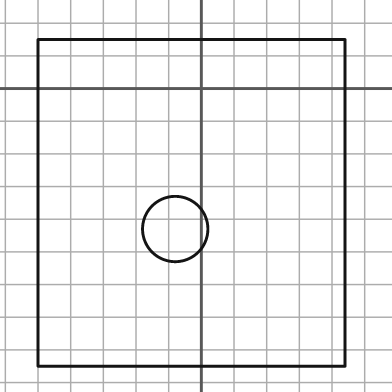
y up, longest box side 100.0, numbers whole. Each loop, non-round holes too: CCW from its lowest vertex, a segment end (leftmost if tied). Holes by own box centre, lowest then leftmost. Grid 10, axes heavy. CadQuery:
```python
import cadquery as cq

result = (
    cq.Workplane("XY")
    .moveTo(-50.0, -85.0)
    .lineTo(44.0, -85.0)
    .lineTo(44.0, 15.0)
    .lineTo(-50.0, 15.0)
    .close()
    .moveTo(-8.0, -43.0)
    .circle(10.0)
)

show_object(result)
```